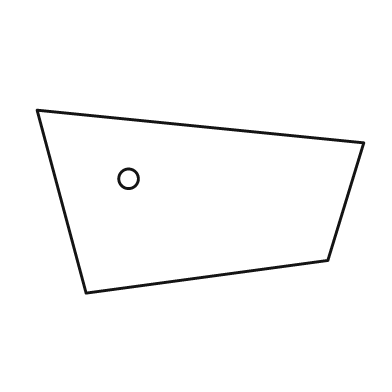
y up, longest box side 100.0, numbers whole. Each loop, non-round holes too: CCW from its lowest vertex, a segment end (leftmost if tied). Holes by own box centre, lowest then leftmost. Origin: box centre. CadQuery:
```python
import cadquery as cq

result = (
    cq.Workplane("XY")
    .moveTo(-35.0, -28.0)
    .lineTo(39.0, -18.0)
    .lineTo(50.0, 18.0)
    .lineTo(-50.0, 28.0)
    .close()
    .moveTo(-22.0, 7.0)
    .circle(3.0)
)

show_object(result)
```